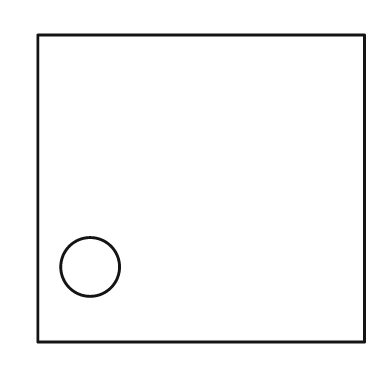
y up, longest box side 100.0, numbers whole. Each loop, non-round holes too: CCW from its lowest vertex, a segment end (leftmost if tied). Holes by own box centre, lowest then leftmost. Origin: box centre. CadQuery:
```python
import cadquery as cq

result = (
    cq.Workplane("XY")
    .moveTo(-50.0, -47.0)
    .lineTo(50.0, -47.0)
    .lineTo(50.0, 47.0)
    .lineTo(-50.0, 47.0)
    .close()
    .moveTo(-34.0, -24.0)
    .circle(9.0)
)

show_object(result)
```